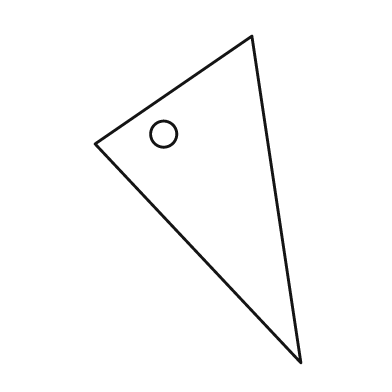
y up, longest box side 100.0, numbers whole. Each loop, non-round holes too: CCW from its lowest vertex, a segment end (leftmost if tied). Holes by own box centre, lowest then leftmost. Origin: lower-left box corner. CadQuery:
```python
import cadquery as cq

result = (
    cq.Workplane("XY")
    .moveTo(63.0, 0.0)
    .lineTo(48.0, 100.0)
    .lineTo(0.0, 67.0)
    .close()
    .moveTo(21.0, 70.0)
    .circle(4.0)
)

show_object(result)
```